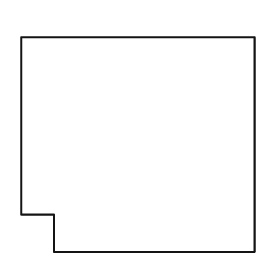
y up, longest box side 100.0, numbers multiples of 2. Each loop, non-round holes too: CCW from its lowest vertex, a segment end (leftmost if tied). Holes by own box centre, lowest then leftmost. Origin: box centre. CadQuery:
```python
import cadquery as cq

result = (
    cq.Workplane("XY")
    .moveTo(-36.0, -46.0)
    .lineTo(50.0, -46.0)
    .lineTo(50.0, 46.0)
    .lineTo(-50.0, 46.0)
    .lineTo(-50.0, -30.0)
    .lineTo(-36.0, -30.0)
    .close()
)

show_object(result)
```